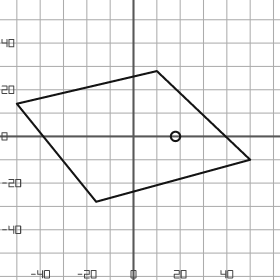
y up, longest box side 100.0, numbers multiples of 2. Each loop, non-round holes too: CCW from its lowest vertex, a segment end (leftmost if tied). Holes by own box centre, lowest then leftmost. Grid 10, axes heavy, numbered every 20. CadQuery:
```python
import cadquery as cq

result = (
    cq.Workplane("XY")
    .moveTo(-16.0, -28.0)
    .lineTo(50.0, -10.0)
    .lineTo(10.0, 28.0)
    .lineTo(-50.0, 14.0)
    .close()
    .moveTo(18.0, 0.0)
    .circle(2.0)
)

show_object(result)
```